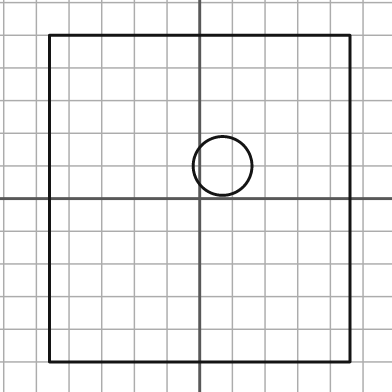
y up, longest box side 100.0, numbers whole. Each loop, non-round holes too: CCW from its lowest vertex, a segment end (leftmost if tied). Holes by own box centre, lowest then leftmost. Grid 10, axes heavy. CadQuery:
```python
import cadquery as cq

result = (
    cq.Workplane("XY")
    .moveTo(-46.0, -50.0)
    .lineTo(46.0, -50.0)
    .lineTo(46.0, 50.0)
    .lineTo(-46.0, 50.0)
    .close()
    .moveTo(7.0, 10.0)
    .circle(9.0)
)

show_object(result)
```